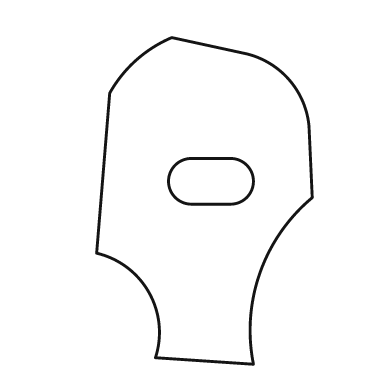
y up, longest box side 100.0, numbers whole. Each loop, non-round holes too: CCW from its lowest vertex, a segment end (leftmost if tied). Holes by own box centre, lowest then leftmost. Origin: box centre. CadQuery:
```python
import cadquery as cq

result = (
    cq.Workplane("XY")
    .moveTo(15.0, -50.0)
    .threePointArc((17.0, -22.0), (33.0, 1.0))
    .lineTo(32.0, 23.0)
    .threePointArc((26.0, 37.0), (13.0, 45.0))
    .lineTo(-10.0, 50.0)
    .threePointArc((-21.0, 43.0), (-29.0, 33.0))
    .lineTo(-33.0, -16.0)
    .threePointArc((-17.0, -28.0), (-15.0, -48.0))
    .close()
    .moveTo(-4.0, -1.0)
    .lineTo(8.0, -1.0)
    .threePointArc((15.0, 6.0), (8.0, 13.0))
    .lineTo(-4.0, 13.0)
    .threePointArc((-11.0, 6.0), (-4.0, -1.0))
    .close()
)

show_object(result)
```